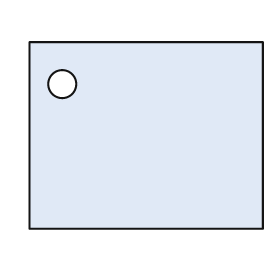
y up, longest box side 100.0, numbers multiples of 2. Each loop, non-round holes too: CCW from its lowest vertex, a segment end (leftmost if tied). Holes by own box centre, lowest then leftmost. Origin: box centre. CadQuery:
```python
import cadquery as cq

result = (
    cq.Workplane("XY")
    .moveTo(-50.0, -40.0)
    .lineTo(50.0, -40.0)
    .lineTo(50.0, 40.0)
    .lineTo(-50.0, 40.0)
    .close()
    .moveTo(-36.0, 22.0)
    .circle(6.0)
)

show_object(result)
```